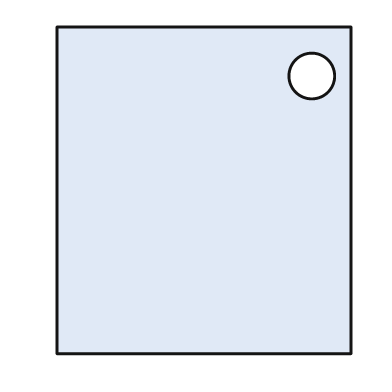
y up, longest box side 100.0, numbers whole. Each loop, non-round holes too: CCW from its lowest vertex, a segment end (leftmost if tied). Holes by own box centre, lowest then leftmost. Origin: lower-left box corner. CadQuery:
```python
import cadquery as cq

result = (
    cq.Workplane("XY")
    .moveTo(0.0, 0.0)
    .lineTo(90.0, 0.0)
    .lineTo(90.0, 100.0)
    .lineTo(0.0, 100.0)
    .close()
    .moveTo(78.0, 85.0)
    .circle(7.0)
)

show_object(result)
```